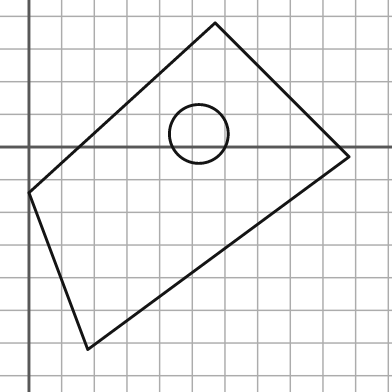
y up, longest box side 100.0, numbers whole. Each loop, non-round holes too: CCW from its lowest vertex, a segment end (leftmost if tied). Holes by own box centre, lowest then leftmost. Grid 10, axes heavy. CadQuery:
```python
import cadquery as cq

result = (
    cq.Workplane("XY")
    .moveTo(18.0, -62.0)
    .lineTo(98.0, -3.0)
    .lineTo(57.0, 38.0)
    .lineTo(0.0, -14.0)
    .close()
    .moveTo(52.0, 4.0)
    .circle(9.0)
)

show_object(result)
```